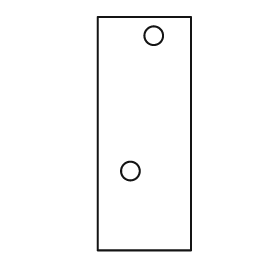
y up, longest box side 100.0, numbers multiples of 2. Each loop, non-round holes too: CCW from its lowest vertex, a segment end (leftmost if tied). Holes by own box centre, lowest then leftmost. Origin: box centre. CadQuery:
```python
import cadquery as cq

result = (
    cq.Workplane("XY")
    .moveTo(-20.0, -50.0)
    .lineTo(20.0, -50.0)
    .lineTo(20.0, 50.0)
    .lineTo(-20.0, 50.0)
    .close()
    .moveTo(-6.0, -16.0)
    .circle(4.0)
    .moveTo(4.0, 42.0)
    .circle(4.0)
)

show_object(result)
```